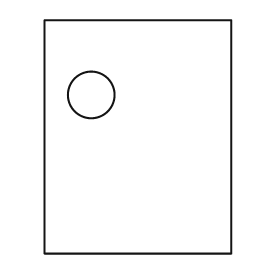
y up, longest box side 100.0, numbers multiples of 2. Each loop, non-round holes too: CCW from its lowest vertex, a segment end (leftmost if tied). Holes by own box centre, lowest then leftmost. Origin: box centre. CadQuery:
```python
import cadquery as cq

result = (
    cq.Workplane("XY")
    .moveTo(-40.0, -50.0)
    .lineTo(40.0, -50.0)
    .lineTo(40.0, 50.0)
    .lineTo(-40.0, 50.0)
    .close()
    .moveTo(-20.0, 18.0)
    .circle(10.0)
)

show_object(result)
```